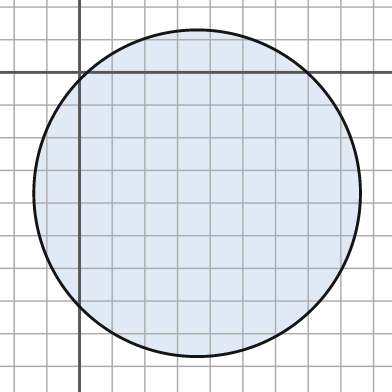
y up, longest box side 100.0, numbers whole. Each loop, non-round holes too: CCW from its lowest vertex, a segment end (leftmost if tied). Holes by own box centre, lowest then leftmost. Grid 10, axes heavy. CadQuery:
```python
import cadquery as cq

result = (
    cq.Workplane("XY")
    .moveTo(36.0, -37.0)
    .circle(50.0)
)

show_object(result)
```